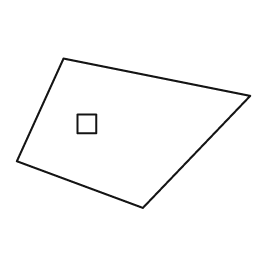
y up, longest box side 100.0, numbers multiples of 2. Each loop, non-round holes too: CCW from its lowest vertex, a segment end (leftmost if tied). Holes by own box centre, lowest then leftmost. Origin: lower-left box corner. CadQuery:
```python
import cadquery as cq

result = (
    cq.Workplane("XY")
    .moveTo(54.0, 0.0)
    .lineTo(100.0, 48.0)
    .lineTo(20.0, 64.0)
    .lineTo(0.0, 20.0)
    .close()
    .moveTo(26.0, 32.0)
    .lineTo(34.0, 32.0)
    .lineTo(34.0, 40.0)
    .lineTo(26.0, 40.0)
    .close()
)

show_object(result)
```